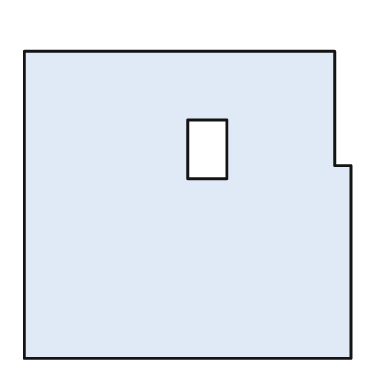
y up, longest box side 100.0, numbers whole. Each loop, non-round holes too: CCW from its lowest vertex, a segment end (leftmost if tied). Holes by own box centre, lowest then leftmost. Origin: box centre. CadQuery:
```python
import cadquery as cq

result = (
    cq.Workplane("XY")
    .moveTo(-50.0, -47.0)
    .lineTo(50.0, -47.0)
    .lineTo(50.0, 12.0)
    .lineTo(45.0, 12.0)
    .lineTo(45.0, 47.0)
    .lineTo(-50.0, 47.0)
    .close()
    .moveTo(0.0, 8.0)
    .lineTo(12.0, 8.0)
    .lineTo(12.0, 26.0)
    .lineTo(0.0, 26.0)
    .close()
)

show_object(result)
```